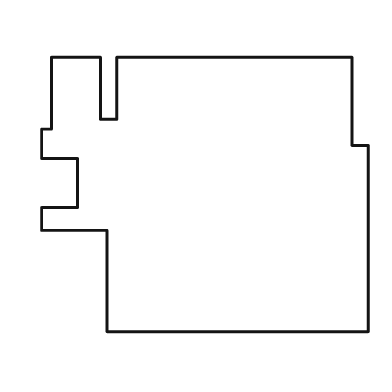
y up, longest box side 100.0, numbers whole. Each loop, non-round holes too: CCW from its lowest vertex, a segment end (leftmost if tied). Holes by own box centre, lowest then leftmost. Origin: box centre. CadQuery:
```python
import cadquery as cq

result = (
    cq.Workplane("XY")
    .moveTo(-30.0, -42.0)
    .lineTo(50.0, -42.0)
    .lineTo(50.0, 15.0)
    .lineTo(45.0, 15.0)
    .lineTo(45.0, 42.0)
    .lineTo(-27.0, 42.0)
    .lineTo(-27.0, 23.0)
    .lineTo(-32.0, 23.0)
    .lineTo(-32.0, 42.0)
    .lineTo(-47.0, 42.0)
    .lineTo(-47.0, 20.0)
    .lineTo(-50.0, 20.0)
    .lineTo(-50.0, 11.0)
    .lineTo(-39.0, 11.0)
    .lineTo(-39.0, -4.0)
    .lineTo(-50.0, -4.0)
    .lineTo(-50.0, -11.0)
    .lineTo(-30.0, -11.0)
    .close()
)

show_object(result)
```